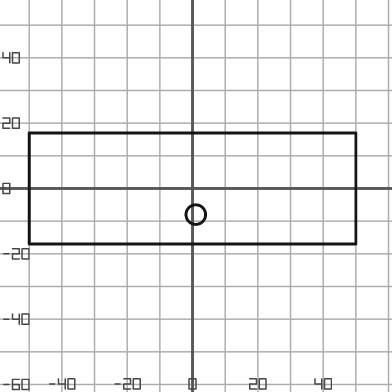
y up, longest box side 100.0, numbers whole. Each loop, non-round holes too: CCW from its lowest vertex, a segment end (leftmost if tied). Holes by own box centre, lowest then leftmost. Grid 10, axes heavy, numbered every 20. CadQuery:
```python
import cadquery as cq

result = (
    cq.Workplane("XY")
    .moveTo(-50.0, -17.0)
    .lineTo(50.0, -17.0)
    .lineTo(50.0, 17.0)
    .lineTo(-50.0, 17.0)
    .close()
    .moveTo(1.0, -8.0)
    .circle(3.0)
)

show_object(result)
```